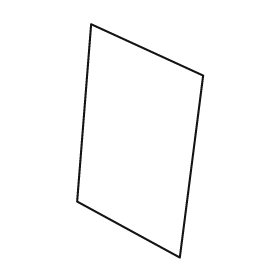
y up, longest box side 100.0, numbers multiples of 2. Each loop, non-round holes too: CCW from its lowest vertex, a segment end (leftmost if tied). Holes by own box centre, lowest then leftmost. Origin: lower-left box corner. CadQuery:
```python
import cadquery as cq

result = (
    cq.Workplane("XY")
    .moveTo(44.0, 0.0)
    .lineTo(54.0, 78.0)
    .lineTo(6.0, 100.0)
    .lineTo(0.0, 24.0)
    .close()
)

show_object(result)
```